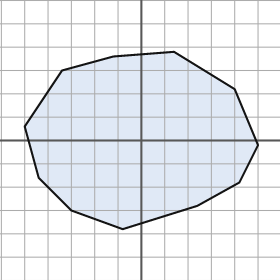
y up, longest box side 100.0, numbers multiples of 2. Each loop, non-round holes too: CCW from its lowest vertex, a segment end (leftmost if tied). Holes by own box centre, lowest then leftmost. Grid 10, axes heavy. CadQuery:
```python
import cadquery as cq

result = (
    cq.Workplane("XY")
    .moveTo(-8.0, -38.0)
    .lineTo(24.0, -28.0)
    .lineTo(42.0, -18.0)
    .lineTo(50.0, -2.0)
    .lineTo(40.0, 22.0)
    .lineTo(14.0, 38.0)
    .lineTo(-12.0, 36.0)
    .lineTo(-34.0, 30.0)
    .lineTo(-50.0, 6.0)
    .lineTo(-44.0, -16.0)
    .lineTo(-30.0, -30.0)
    .close()
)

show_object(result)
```